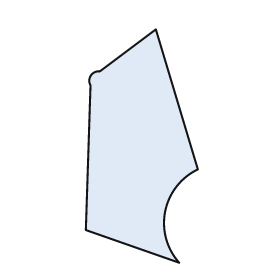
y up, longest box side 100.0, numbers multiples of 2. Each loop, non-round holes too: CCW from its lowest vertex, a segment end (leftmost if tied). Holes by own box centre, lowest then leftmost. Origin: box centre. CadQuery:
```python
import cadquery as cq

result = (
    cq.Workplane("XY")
    .moveTo(16.0, -50.0)
    .threePointArc((10.0, -28.0), (24.0, -10.0))
    .lineTo(6.0, 50.0)
    .lineTo(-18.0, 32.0)
    .threePointArc((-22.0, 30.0), (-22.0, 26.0))
    .lineTo(-24.0, -36.0)
    .close()
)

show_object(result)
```